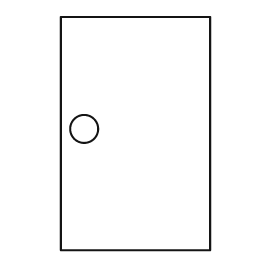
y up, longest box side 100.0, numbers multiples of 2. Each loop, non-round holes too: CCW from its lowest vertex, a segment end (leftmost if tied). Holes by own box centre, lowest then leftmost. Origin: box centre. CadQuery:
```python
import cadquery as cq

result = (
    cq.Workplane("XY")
    .moveTo(-32.0, -50.0)
    .lineTo(32.0, -50.0)
    .lineTo(32.0, 50.0)
    .lineTo(-32.0, 50.0)
    .close()
    .moveTo(-22.0, 2.0)
    .circle(6.0)
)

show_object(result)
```